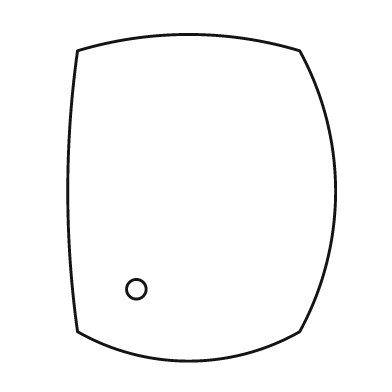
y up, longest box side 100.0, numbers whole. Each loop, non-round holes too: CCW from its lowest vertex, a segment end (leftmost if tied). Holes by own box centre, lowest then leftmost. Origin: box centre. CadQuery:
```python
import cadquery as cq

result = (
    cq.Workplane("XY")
    .moveTo(-38.0, -41.0)
    .threePointArc((-4.0, -50.0), (30.0, -41.0))
    .threePointArc((41.0, 2.0), (30.0, 45.0))
    .threePointArc((-4.0, 50.0), (-38.0, 45.0))
    .threePointArc((-41.0, 2.0), (-38.0, -41.0))
    .close()
    .moveTo(-20.0, -28.0)
    .circle(3.0)
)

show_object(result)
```